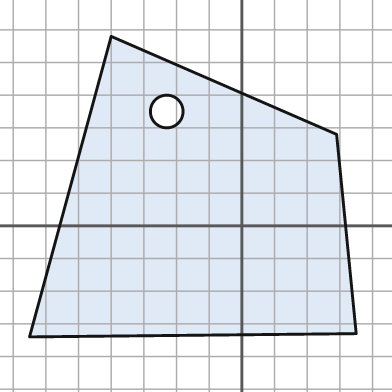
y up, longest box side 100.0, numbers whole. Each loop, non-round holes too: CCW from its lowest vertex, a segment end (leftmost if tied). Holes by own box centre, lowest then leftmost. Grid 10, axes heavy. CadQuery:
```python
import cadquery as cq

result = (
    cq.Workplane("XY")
    .moveTo(-65.0, -34.0)
    .lineTo(35.0, -33.0)
    .lineTo(29.0, 28.0)
    .lineTo(-40.0, 58.0)
    .close()
    .moveTo(-23.0, 35.0)
    .circle(5.0)
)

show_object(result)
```